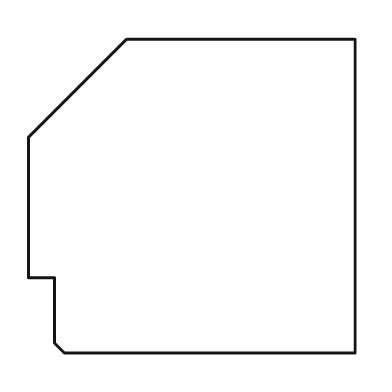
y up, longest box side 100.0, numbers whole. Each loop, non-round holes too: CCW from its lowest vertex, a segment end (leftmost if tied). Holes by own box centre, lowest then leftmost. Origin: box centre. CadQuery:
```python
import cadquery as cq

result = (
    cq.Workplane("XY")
    .moveTo(-39.0, -48.0)
    .lineTo(50.0, -48.0)
    .lineTo(50.0, 48.0)
    .lineTo(-20.0, 48.0)
    .lineTo(-50.0, 18.0)
    .lineTo(-50.0, -25.0)
    .lineTo(-42.0, -25.0)
    .lineTo(-42.0, -45.0)
    .close()
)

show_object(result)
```